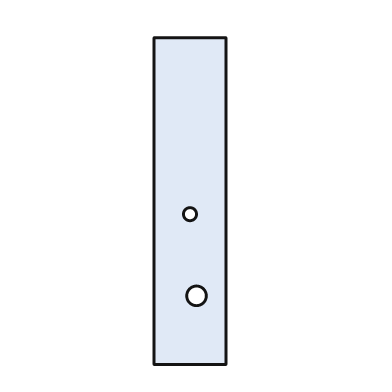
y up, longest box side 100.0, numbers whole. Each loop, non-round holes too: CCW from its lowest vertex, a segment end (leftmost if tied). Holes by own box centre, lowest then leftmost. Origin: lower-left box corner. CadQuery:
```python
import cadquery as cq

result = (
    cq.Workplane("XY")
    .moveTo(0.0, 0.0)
    .lineTo(22.0, 0.0)
    .lineTo(22.0, 100.0)
    .lineTo(0.0, 100.0)
    .close()
    .moveTo(13.0, 21.0)
    .circle(3.0)
    .moveTo(11.0, 46.0)
    .circle(2.0)
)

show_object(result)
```